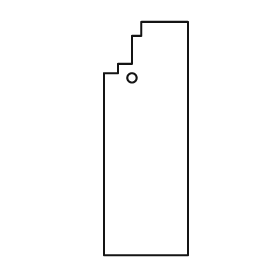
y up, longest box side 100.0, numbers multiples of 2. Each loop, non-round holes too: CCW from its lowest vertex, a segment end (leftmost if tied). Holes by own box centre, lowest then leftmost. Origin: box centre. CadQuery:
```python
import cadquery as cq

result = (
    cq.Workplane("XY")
    .moveTo(-18.0, -50.0)
    .lineTo(18.0, -50.0)
    .lineTo(18.0, 50.0)
    .lineTo(-2.0, 50.0)
    .lineTo(-2.0, 44.0)
    .lineTo(-6.0, 44.0)
    .lineTo(-6.0, 32.0)
    .lineTo(-12.0, 32.0)
    .lineTo(-12.0, 28.0)
    .lineTo(-18.0, 28.0)
    .close()
    .moveTo(-6.0, 26.0)
    .circle(2.0)
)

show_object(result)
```